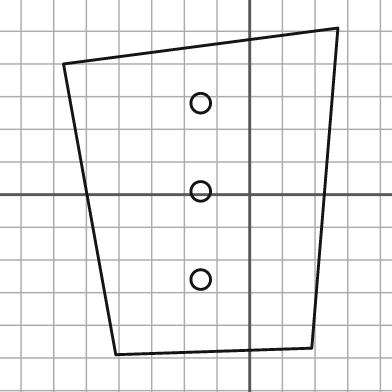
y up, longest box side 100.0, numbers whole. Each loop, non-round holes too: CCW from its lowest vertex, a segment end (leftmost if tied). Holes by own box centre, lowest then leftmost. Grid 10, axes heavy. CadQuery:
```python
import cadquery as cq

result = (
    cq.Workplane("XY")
    .moveTo(-41.0, -49.0)
    .lineTo(19.0, -47.0)
    .lineTo(27.0, 51.0)
    .lineTo(-57.0, 40.0)
    .close()
    .moveTo(-15.0, -26.0)
    .circle(3.0)
    .moveTo(-15.0, 1.0)
    .circle(3.0)
    .moveTo(-15.0, 28.0)
    .circle(3.0)
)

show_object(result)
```